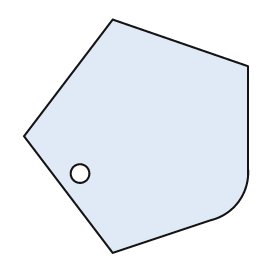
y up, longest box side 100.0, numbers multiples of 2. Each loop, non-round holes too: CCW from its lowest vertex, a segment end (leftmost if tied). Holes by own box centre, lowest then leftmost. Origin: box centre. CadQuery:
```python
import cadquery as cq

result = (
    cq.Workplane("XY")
    .moveTo(-10.0, -50.0)
    .lineTo(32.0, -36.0)
    .threePointArc((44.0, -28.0), (48.0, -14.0))
    .lineTo(48.0, 30.0)
    .lineTo(-10.0, 50.0)
    .lineTo(-48.0, 0.0)
    .close()
    .moveTo(-24.0, -16.0)
    .circle(4.0)
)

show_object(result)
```